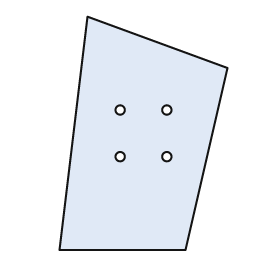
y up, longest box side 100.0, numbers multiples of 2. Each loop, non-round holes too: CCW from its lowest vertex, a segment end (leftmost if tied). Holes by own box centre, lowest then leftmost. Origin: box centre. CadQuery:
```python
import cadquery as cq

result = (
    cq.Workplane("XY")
    .moveTo(-36.0, -50.0)
    .lineTo(18.0, -50.0)
    .lineTo(36.0, 28.0)
    .lineTo(-24.0, 50.0)
    .close()
    .moveTo(-10.0, -10.0)
    .circle(2.0)
    .moveTo(10.0, -10.0)
    .circle(2.0)
    .moveTo(-10.0, 10.0)
    .circle(2.0)
    .moveTo(10.0, 10.0)
    .circle(2.0)
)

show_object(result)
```